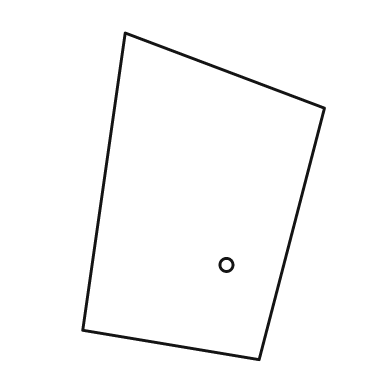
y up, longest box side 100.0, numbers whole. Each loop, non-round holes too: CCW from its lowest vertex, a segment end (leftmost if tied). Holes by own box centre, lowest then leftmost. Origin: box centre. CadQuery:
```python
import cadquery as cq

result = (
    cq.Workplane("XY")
    .moveTo(17.0, -50.0)
    .lineTo(37.0, 27.0)
    .lineTo(-24.0, 50.0)
    .lineTo(-37.0, -41.0)
    .close()
    .moveTo(7.0, -21.0)
    .circle(2.0)
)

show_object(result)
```